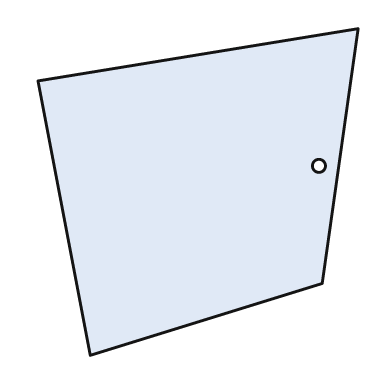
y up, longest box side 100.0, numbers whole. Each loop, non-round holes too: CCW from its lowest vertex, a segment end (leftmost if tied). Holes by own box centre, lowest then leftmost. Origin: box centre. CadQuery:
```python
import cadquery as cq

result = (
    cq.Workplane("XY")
    .moveTo(-33.0, -50.0)
    .lineTo(38.0, -28.0)
    .lineTo(49.0, 50.0)
    .lineTo(-49.0, 34.0)
    .close()
    .moveTo(37.0, 8.0)
    .circle(2.0)
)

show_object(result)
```